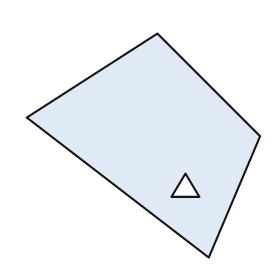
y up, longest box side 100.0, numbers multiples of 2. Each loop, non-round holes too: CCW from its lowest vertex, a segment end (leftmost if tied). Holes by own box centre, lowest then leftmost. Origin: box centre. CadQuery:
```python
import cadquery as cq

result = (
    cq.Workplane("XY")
    .moveTo(28.0, -48.0)
    .lineTo(50.0, 4.0)
    .lineTo(6.0, 48.0)
    .lineTo(-50.0, 12.0)
    .close()
    .moveTo(12.0, -22.0)
    .lineTo(24.0, -22.0)
    .lineTo(18.0, -12.0)
    .close()
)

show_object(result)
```